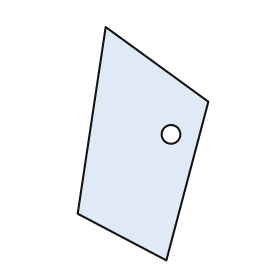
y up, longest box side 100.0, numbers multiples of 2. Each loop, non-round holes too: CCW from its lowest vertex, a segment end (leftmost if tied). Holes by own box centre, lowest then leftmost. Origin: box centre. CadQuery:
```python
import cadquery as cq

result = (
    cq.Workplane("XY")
    .moveTo(10.0, -50.0)
    .lineTo(28.0, 18.0)
    .lineTo(-16.0, 50.0)
    .lineTo(-28.0, -30.0)
    .close()
    .moveTo(12.0, 4.0)
    .circle(4.0)
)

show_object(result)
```